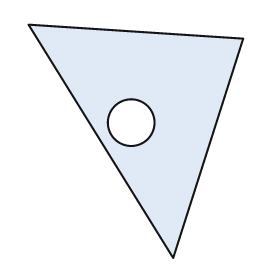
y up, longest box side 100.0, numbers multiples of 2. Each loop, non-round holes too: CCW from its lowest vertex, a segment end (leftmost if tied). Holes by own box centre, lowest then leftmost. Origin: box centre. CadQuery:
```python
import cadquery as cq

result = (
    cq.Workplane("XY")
    .moveTo(16.0, -50.0)
    .lineTo(46.0, 44.0)
    .lineTo(-46.0, 50.0)
    .close()
    .moveTo(-2.0, 8.0)
    .circle(10.0)
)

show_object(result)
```